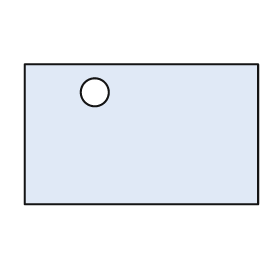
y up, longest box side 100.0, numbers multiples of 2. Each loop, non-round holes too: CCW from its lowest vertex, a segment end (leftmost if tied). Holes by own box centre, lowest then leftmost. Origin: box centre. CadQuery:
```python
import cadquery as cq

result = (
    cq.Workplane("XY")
    .moveTo(-50.0, -30.0)
    .lineTo(50.0, -30.0)
    .lineTo(50.0, 30.0)
    .lineTo(-50.0, 30.0)
    .close()
    .moveTo(-20.0, 18.0)
    .circle(6.0)
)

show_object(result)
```